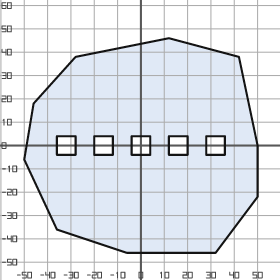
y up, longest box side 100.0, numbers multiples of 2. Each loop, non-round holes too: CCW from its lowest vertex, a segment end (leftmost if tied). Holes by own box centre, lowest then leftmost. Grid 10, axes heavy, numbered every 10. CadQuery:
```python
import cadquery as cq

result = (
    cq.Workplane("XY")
    .moveTo(-6.0, -46.0)
    .lineTo(32.0, -46.0)
    .lineTo(50.0, -22.0)
    .lineTo(50.0, 0.0)
    .lineTo(42.0, 38.0)
    .lineTo(12.0, 46.0)
    .lineTo(-28.0, 38.0)
    .lineTo(-46.0, 18.0)
    .lineTo(-50.0, -6.0)
    .lineTo(-36.0, -36.0)
    .close()
    .moveTo(-36.0, -4.0)
    .lineTo(-28.0, -4.0)
    .lineTo(-28.0, 4.0)
    .lineTo(-36.0, 4.0)
    .close()
    .moveTo(-20.0, -4.0)
    .lineTo(-12.0, -4.0)
    .lineTo(-12.0, 4.0)
    .lineTo(-20.0, 4.0)
    .close()
    .moveTo(-4.0, -4.0)
    .lineTo(4.0, -4.0)
    .lineTo(4.0, 4.0)
    .lineTo(-4.0, 4.0)
    .close()
    .moveTo(12.0, -4.0)
    .lineTo(20.0, -4.0)
    .lineTo(20.0, 4.0)
    .lineTo(12.0, 4.0)
    .close()
    .moveTo(28.0, -4.0)
    .lineTo(36.0, -4.0)
    .lineTo(36.0, 4.0)
    .lineTo(28.0, 4.0)
    .close()
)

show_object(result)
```